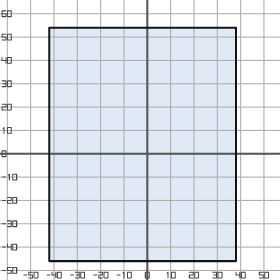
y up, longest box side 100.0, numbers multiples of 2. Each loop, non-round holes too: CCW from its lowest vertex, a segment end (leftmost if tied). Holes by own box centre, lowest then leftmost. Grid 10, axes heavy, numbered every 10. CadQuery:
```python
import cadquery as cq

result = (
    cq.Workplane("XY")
    .moveTo(-42.0, -46.0)
    .lineTo(38.0, -46.0)
    .lineTo(38.0, 54.0)
    .lineTo(-42.0, 54.0)
    .close()
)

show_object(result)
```